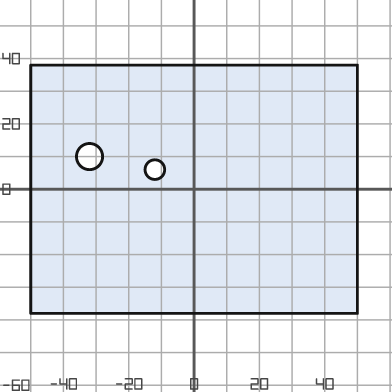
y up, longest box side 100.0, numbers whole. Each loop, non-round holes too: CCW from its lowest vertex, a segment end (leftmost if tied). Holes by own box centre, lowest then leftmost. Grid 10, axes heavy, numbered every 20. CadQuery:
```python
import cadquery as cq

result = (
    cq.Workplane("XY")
    .moveTo(-50.0, -38.0)
    .lineTo(50.0, -38.0)
    .lineTo(50.0, 38.0)
    .lineTo(-50.0, 38.0)
    .close()
    .moveTo(-12.0, 6.0)
    .circle(3.0)
    .moveTo(-32.0, 10.0)
    .circle(4.0)
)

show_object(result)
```